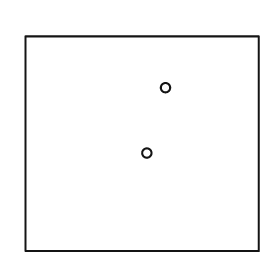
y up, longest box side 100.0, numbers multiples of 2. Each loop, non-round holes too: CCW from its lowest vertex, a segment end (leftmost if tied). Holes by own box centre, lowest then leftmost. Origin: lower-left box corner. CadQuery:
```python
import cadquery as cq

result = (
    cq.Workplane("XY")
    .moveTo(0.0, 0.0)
    .lineTo(100.0, 0.0)
    .lineTo(100.0, 92.0)
    .lineTo(0.0, 92.0)
    .close()
    .moveTo(52.0, 42.0)
    .circle(2.0)
    .moveTo(60.0, 70.0)
    .circle(2.0)
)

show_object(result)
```